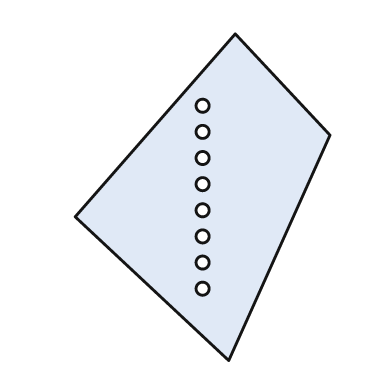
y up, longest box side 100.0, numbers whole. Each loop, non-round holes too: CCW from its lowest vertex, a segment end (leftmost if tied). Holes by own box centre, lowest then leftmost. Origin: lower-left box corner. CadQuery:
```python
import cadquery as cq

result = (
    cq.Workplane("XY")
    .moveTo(47.0, 0.0)
    .lineTo(78.0, 69.0)
    .lineTo(49.0, 100.0)
    .lineTo(0.0, 44.0)
    .close()
    .moveTo(39.0, 22.0)
    .circle(2.0)
    .moveTo(39.0, 30.0)
    .circle(2.0)
    .moveTo(39.0, 38.0)
    .circle(2.0)
    .moveTo(39.0, 46.0)
    .circle(2.0)
    .moveTo(39.0, 54.0)
    .circle(2.0)
    .moveTo(39.0, 62.0)
    .circle(2.0)
    .moveTo(39.0, 70.0)
    .circle(2.0)
    .moveTo(39.0, 78.0)
    .circle(2.0)
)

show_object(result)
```